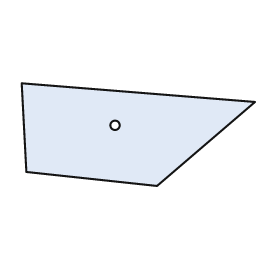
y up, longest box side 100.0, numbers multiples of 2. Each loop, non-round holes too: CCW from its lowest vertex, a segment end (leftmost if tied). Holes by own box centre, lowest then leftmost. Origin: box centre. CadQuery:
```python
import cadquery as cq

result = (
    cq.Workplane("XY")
    .moveTo(8.0, -22.0)
    .lineTo(50.0, 14.0)
    .lineTo(-50.0, 22.0)
    .lineTo(-48.0, -16.0)
    .close()
    .moveTo(-10.0, 4.0)
    .circle(2.0)
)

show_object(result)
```